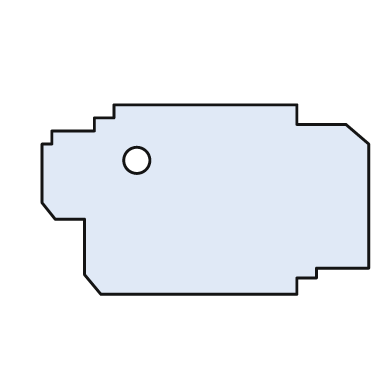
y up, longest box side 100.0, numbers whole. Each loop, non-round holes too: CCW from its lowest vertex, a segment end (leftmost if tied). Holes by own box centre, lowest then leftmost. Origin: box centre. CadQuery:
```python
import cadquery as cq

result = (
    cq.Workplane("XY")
    .moveTo(-32.0, -29.0)
    .lineTo(28.0, -29.0)
    .lineTo(28.0, -24.0)
    .lineTo(34.0, -24.0)
    .lineTo(34.0, -21.0)
    .lineTo(50.0, -21.0)
    .lineTo(50.0, 17.0)
    .lineTo(43.0, 23.0)
    .lineTo(28.0, 23.0)
    .lineTo(28.0, 29.0)
    .lineTo(-28.0, 29.0)
    .lineTo(-28.0, 25.0)
    .lineTo(-34.0, 25.0)
    .lineTo(-34.0, 21.0)
    .lineTo(-47.0, 21.0)
    .lineTo(-47.0, 17.0)
    .lineTo(-50.0, 17.0)
    .lineTo(-50.0, -1.0)
    .lineTo(-46.0, -6.0)
    .lineTo(-37.0, -6.0)
    .lineTo(-37.0, -23.0)
    .close()
    .moveTo(-21.0, 12.0)
    .circle(4.0)
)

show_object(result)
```